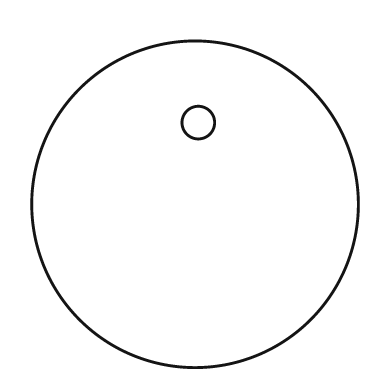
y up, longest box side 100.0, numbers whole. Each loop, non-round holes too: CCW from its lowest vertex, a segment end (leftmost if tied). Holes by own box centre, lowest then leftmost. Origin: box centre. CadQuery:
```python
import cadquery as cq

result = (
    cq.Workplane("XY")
    .moveTo(0.0, 0.0)
    .circle(50.0)
    .moveTo(1.0, 25.0)
    .circle(5.0)
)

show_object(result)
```